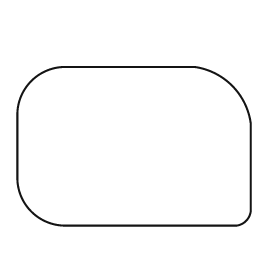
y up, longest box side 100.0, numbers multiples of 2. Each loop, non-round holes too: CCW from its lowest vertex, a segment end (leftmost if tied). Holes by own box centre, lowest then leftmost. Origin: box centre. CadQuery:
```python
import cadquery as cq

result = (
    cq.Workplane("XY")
    .moveTo(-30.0, -34.0)
    .lineTo(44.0, -34.0)
    .threePointArc((48.0, -32.0), (50.0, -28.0))
    .lineTo(50.0, 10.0)
    .threePointArc((42.0, 26.0), (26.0, 34.0))
    .lineTo(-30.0, 34.0)
    .threePointArc((-44.0, 28.0), (-50.0, 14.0))
    .lineTo(-50.0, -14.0)
    .threePointArc((-44.0, -28.0), (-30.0, -34.0))
    .close()
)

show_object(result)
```